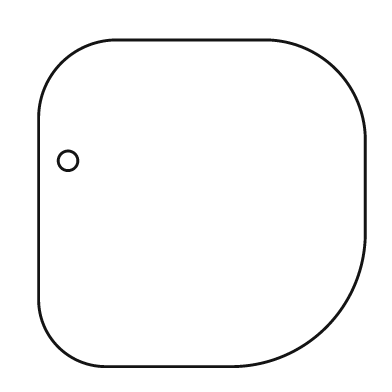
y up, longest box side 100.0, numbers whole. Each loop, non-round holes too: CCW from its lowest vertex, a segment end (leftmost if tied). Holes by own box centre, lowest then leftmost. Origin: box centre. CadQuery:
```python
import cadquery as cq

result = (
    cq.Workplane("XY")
    .moveTo(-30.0, -50.0)
    .lineTo(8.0, -50.0)
    .threePointArc((38.0, -38.0), (50.0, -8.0))
    .lineTo(50.0, 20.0)
    .threePointArc((41.0, 41.0), (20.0, 50.0))
    .lineTo(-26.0, 50.0)
    .threePointArc((-43.0, 43.0), (-50.0, 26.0))
    .lineTo(-50.0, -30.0)
    .threePointArc((-44.0, -44.0), (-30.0, -50.0))
    .close()
    .moveTo(-41.0, 13.0)
    .circle(3.0)
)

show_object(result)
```